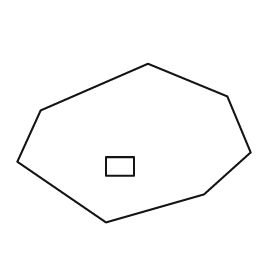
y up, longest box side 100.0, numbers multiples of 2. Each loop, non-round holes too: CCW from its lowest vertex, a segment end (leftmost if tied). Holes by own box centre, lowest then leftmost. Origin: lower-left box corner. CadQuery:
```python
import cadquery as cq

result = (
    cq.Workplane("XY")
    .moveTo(38.0, 0.0)
    .lineTo(80.0, 12.0)
    .lineTo(100.0, 30.0)
    .lineTo(90.0, 54.0)
    .lineTo(56.0, 68.0)
    .lineTo(10.0, 48.0)
    .lineTo(0.0, 26.0)
    .close()
    .moveTo(38.0, 20.0)
    .lineTo(50.0, 20.0)
    .lineTo(50.0, 28.0)
    .lineTo(38.0, 28.0)
    .close()
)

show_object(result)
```